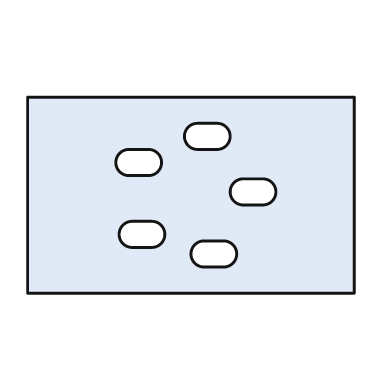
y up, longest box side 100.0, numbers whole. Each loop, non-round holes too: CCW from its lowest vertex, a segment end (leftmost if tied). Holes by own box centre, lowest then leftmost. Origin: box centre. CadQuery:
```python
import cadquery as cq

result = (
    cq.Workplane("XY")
    .moveTo(-50.0, -30.0)
    .lineTo(50.0, -30.0)
    .lineTo(50.0, 30.0)
    .lineTo(-50.0, 30.0)
    .close()
    .moveTo(4.0, -22.0)
    .lineTo(10.0, -22.0)
    .threePointArc((14.0, -18.0), (10.0, -14.0))
    .lineTo(4.0, -14.0)
    .threePointArc((0.0, -18.0), (4.0, -22.0))
    .close()
    .moveTo(-18.0, -16.0)
    .lineTo(-12.0, -16.0)
    .threePointArc((-8.0, -12.0), (-12.0, -8.0))
    .lineTo(-18.0, -8.0)
    .threePointArc((-22.0, -12.0), (-18.0, -16.0))
    .close()
    .moveTo(16.0, -3.0)
    .lineTo(22.0, -3.0)
    .threePointArc((26.0, 1.0), (22.0, 5.0))
    .lineTo(16.0, 5.0)
    .threePointArc((12.0, 1.0), (16.0, -3.0))
    .close()
    .moveTo(-19.0, 6.0)
    .lineTo(-13.0, 6.0)
    .threePointArc((-9.0, 10.0), (-13.0, 14.0))
    .lineTo(-19.0, 14.0)
    .threePointArc((-23.0, 10.0), (-19.0, 6.0))
    .close()
    .moveTo(2.0, 14.0)
    .lineTo(8.0, 14.0)
    .threePointArc((12.0, 18.0), (8.0, 22.0))
    .lineTo(2.0, 22.0)
    .threePointArc((-2.0, 18.0), (2.0, 14.0))
    .close()
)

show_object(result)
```